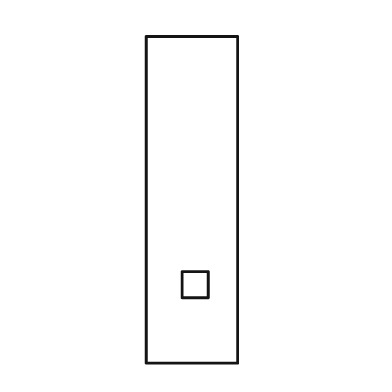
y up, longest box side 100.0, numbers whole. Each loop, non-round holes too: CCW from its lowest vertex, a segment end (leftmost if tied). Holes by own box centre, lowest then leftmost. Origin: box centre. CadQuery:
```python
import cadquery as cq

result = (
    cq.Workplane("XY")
    .moveTo(-14.0, -50.0)
    .lineTo(14.0, -50.0)
    .lineTo(14.0, 50.0)
    .lineTo(-14.0, 50.0)
    .close()
    .moveTo(-3.0, -30.0)
    .lineTo(5.0, -30.0)
    .lineTo(5.0, -22.0)
    .lineTo(-3.0, -22.0)
    .close()
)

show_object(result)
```